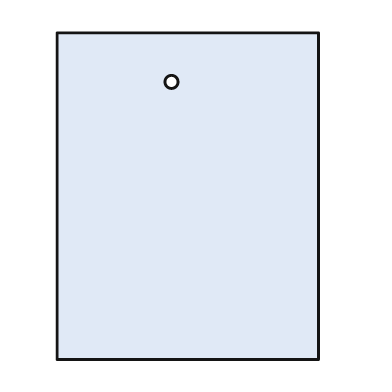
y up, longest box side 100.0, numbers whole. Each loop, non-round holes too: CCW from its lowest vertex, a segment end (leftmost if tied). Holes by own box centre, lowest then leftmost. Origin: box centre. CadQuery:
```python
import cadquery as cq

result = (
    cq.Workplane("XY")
    .moveTo(-40.0, -50.0)
    .lineTo(40.0, -50.0)
    .lineTo(40.0, 50.0)
    .lineTo(-40.0, 50.0)
    .close()
    .moveTo(-5.0, 35.0)
    .circle(2.0)
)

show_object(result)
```